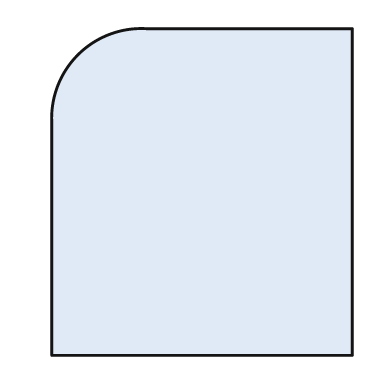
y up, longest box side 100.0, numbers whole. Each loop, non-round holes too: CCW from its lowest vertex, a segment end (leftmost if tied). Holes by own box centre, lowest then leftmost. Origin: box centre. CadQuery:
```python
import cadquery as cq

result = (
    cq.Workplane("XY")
    .moveTo(-46.0, -50.0)
    .lineTo(46.0, -50.0)
    .lineTo(46.0, 50.0)
    .lineTo(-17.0, 50.0)
    .threePointArc((-38.0, 42.0), (-46.0, 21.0))
    .close()
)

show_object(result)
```